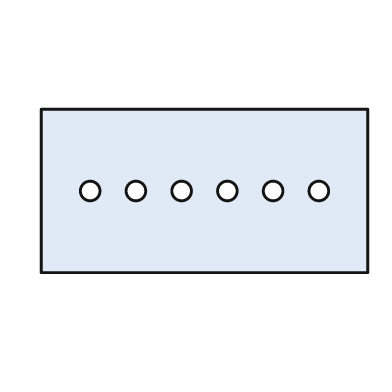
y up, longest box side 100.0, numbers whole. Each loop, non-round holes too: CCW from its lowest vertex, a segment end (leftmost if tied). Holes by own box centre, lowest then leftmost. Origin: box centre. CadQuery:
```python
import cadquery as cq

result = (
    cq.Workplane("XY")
    .moveTo(-50.0, -25.0)
    .lineTo(50.0, -25.0)
    .lineTo(50.0, 25.0)
    .lineTo(-50.0, 25.0)
    .close()
    .moveTo(-35.0, 0.0)
    .circle(3.0)
    .moveTo(-21.0, 0.0)
    .circle(3.0)
    .moveTo(-7.0, 0.0)
    .circle(3.0)
    .moveTo(7.0, 0.0)
    .circle(3.0)
    .moveTo(21.0, 0.0)
    .circle(3.0)
    .moveTo(35.0, 0.0)
    .circle(3.0)
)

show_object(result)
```